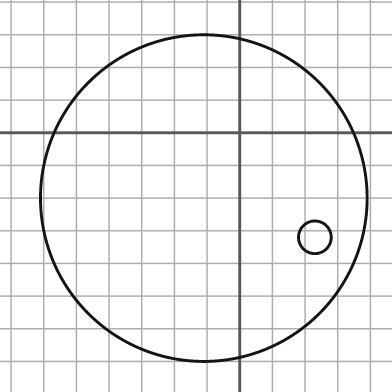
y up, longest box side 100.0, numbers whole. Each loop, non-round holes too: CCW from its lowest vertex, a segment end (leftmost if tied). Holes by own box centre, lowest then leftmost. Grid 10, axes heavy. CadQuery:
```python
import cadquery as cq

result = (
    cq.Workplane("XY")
    .moveTo(-11.0, -20.0)
    .circle(50.0)
    .moveTo(23.0, -32.0)
    .circle(5.0)
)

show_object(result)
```